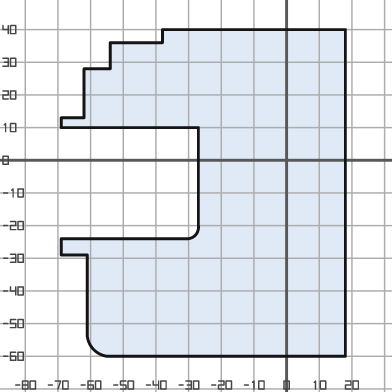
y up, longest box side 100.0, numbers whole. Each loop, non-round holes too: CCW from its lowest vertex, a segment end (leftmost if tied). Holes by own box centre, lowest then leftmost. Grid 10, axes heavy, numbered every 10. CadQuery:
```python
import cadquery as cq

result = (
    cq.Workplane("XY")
    .moveTo(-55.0, -60.0)
    .lineTo(18.0, -60.0)
    .lineTo(18.0, 40.0)
    .lineTo(-38.0, 40.0)
    .lineTo(-38.0, 36.0)
    .lineTo(-54.0, 36.0)
    .lineTo(-54.0, 28.0)
    .lineTo(-62.0, 28.0)
    .lineTo(-62.0, 13.0)
    .lineTo(-69.0, 13.0)
    .lineTo(-69.0, 10.0)
    .lineTo(-27.0, 10.0)
    .lineTo(-27.0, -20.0)
    .threePointArc((-28.0, -23.0), (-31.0, -24.0))
    .lineTo(-69.0, -24.0)
    .lineTo(-69.0, -29.0)
    .lineTo(-61.0, -29.0)
    .lineTo(-61.0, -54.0)
    .threePointArc((-59.0, -58.0), (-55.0, -60.0))
    .close()
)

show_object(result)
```